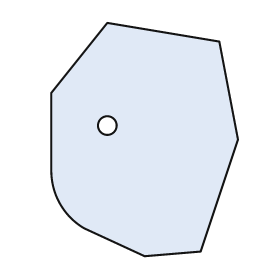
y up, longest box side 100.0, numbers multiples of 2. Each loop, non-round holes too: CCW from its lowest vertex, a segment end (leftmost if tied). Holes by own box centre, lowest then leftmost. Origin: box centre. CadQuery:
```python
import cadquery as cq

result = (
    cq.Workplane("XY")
    .moveTo(0.0, -50.0)
    .lineTo(24.0, -48.0)
    .lineTo(40.0, 0.0)
    .lineTo(32.0, 42.0)
    .lineTo(-16.0, 50.0)
    .lineTo(-40.0, 20.0)
    .lineTo(-40.0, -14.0)
    .threePointArc((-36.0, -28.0), (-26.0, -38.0))
    .close()
    .moveTo(-16.0, 6.0)
    .circle(4.0)
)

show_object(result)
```